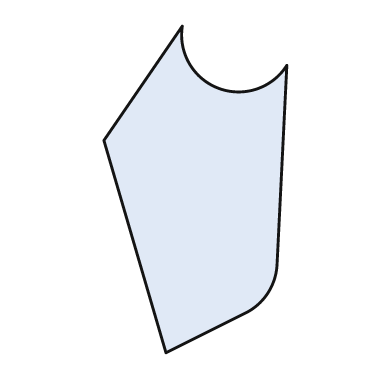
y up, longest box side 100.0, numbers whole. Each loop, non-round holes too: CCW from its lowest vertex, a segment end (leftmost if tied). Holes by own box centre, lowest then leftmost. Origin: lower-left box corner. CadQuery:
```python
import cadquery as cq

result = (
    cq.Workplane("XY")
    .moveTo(19.0, 0.0)
    .lineTo(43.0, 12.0)
    .threePointArc((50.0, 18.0), (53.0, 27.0))
    .lineTo(56.0, 88.0)
    .threePointArc((35.0, 81.0), (24.0, 100.0))
    .lineTo(0.0, 65.0)
    .close()
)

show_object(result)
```